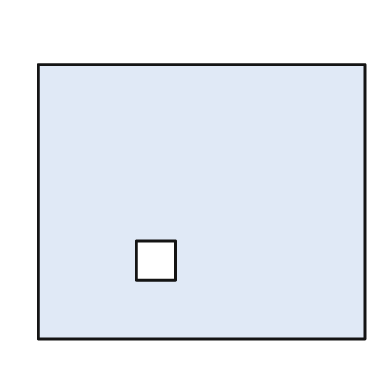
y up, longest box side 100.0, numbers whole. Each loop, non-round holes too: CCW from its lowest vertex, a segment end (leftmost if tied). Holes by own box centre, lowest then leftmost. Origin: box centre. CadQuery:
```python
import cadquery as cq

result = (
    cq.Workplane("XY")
    .moveTo(-50.0, -42.0)
    .lineTo(50.0, -42.0)
    .lineTo(50.0, 42.0)
    .lineTo(-50.0, 42.0)
    .close()
    .moveTo(-20.0, -24.0)
    .lineTo(-8.0, -24.0)
    .lineTo(-8.0, -12.0)
    .lineTo(-20.0, -12.0)
    .close()
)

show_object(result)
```